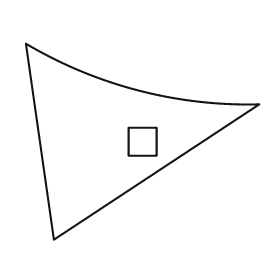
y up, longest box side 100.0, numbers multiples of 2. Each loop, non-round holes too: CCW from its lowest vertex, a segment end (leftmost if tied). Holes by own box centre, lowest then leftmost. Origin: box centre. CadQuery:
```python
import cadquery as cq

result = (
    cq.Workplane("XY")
    .moveTo(-38.0, -42.0)
    .lineTo(50.0, 16.0)
    .threePointArc((-2.0, 22.0), (-50.0, 42.0))
    .close()
    .moveTo(-6.0, -6.0)
    .lineTo(6.0, -6.0)
    .lineTo(6.0, 6.0)
    .lineTo(-6.0, 6.0)
    .close()
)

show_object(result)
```